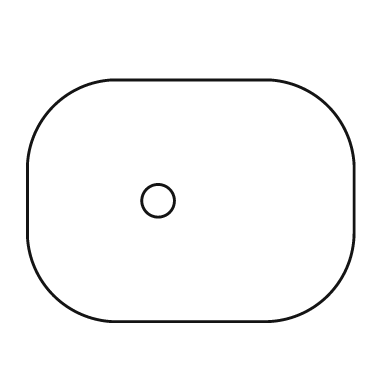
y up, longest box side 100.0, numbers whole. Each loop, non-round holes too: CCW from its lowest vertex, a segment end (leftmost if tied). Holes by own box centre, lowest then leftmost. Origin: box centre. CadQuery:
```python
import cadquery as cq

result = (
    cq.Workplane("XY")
    .moveTo(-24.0, -37.0)
    .lineTo(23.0, -37.0)
    .threePointArc((42.0, -29.0), (50.0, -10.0))
    .lineTo(50.0, 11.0)
    .threePointArc((42.0, 29.0), (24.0, 37.0))
    .lineTo(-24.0, 37.0)
    .threePointArc((-42.0, 29.0), (-50.0, 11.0))
    .lineTo(-50.0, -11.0)
    .threePointArc((-42.0, -29.0), (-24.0, -37.0))
    .close()
    .moveTo(-10.0, 0.0)
    .circle(5.0)
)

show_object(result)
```